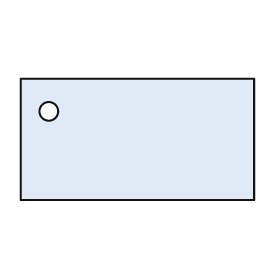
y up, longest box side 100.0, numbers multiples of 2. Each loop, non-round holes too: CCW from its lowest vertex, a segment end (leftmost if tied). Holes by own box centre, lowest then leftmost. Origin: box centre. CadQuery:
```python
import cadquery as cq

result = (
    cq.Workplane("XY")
    .moveTo(-50.0, -26.0)
    .lineTo(50.0, -26.0)
    .lineTo(50.0, 26.0)
    .lineTo(-50.0, 26.0)
    .close()
    .moveTo(-38.0, 12.0)
    .circle(4.0)
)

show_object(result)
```